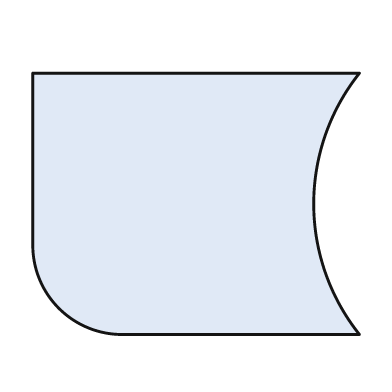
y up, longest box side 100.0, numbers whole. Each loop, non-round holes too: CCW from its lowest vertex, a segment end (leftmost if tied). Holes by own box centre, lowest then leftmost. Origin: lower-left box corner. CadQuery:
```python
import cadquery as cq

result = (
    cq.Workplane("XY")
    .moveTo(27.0, 0.0)
    .lineTo(100.0, 0.0)
    .threePointArc((86.0, 40.0), (100.0, 80.0))
    .lineTo(0.0, 80.0)
    .lineTo(0.0, 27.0)
    .threePointArc((8.0, 8.0), (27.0, 0.0))
    .close()
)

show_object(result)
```